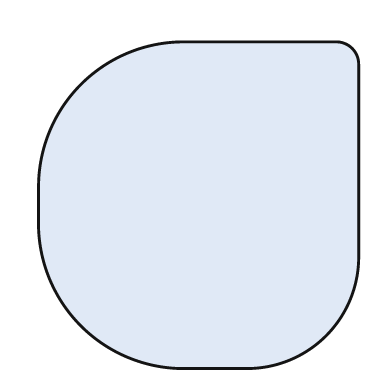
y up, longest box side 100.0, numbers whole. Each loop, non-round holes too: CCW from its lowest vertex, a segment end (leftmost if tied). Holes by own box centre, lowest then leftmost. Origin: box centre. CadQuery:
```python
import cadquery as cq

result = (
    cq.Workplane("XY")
    .moveTo(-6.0, -50.0)
    .lineTo(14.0, -50.0)
    .threePointArc((39.0, -40.0), (49.0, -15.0))
    .lineTo(49.0, 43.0)
    .threePointArc((47.0, 48.0), (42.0, 50.0))
    .lineTo(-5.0, 50.0)
    .threePointArc((-36.0, 37.0), (-49.0, 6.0))
    .lineTo(-49.0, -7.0)
    .threePointArc((-36.0, -37.0), (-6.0, -50.0))
    .close()
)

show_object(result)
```